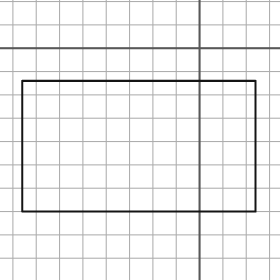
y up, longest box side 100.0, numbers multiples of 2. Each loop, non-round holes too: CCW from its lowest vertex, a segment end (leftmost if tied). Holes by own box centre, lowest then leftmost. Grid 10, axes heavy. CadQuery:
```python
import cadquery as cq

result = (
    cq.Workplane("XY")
    .moveTo(-76.0, -70.0)
    .lineTo(24.0, -70.0)
    .lineTo(24.0, -14.0)
    .lineTo(-76.0, -14.0)
    .close()
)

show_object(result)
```